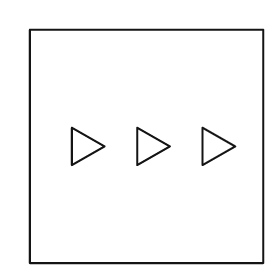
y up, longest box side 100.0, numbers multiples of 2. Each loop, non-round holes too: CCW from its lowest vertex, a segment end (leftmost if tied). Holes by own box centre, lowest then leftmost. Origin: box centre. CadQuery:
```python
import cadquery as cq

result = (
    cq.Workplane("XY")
    .moveTo(-50.0, -50.0)
    .lineTo(50.0, -50.0)
    .lineTo(50.0, 50.0)
    .lineTo(-50.0, 50.0)
    .close()
    .moveTo(-32.0, -8.0)
    .lineTo(-18.0, 0.0)
    .lineTo(-32.0, 8.0)
    .close()
    .moveTo(-4.0, -8.0)
    .lineTo(10.0, 0.0)
    .lineTo(-4.0, 8.0)
    .close()
    .moveTo(24.0, -8.0)
    .lineTo(38.0, 0.0)
    .lineTo(24.0, 8.0)
    .close()
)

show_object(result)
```